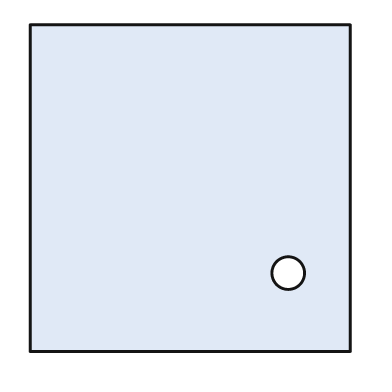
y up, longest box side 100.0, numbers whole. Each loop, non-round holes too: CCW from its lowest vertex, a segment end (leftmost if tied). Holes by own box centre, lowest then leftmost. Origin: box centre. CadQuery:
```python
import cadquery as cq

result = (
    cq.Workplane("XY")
    .moveTo(-49.0, -50.0)
    .lineTo(49.0, -50.0)
    .lineTo(49.0, 50.0)
    .lineTo(-49.0, 50.0)
    .close()
    .moveTo(30.0, -26.0)
    .circle(5.0)
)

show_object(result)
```